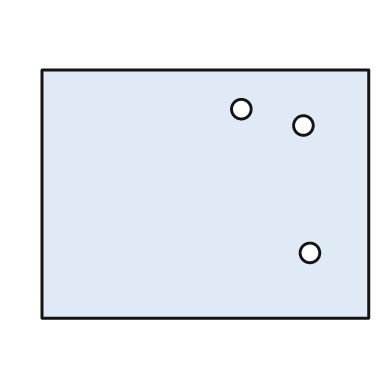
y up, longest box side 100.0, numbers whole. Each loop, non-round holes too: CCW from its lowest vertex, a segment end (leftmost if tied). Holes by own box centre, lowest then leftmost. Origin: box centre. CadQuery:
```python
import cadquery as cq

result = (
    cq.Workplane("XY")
    .moveTo(-50.0, -38.0)
    .lineTo(50.0, -38.0)
    .lineTo(50.0, 38.0)
    .lineTo(-50.0, 38.0)
    .close()
    .moveTo(32.0, -18.0)
    .circle(3.0)
    .moveTo(30.0, 21.0)
    .circle(3.0)
    .moveTo(11.0, 26.0)
    .circle(3.0)
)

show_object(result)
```